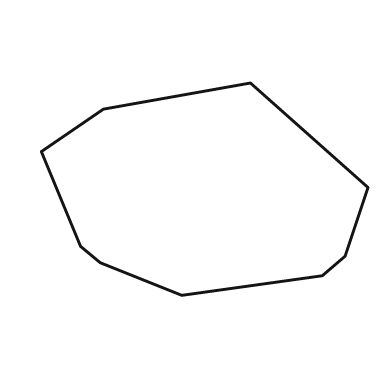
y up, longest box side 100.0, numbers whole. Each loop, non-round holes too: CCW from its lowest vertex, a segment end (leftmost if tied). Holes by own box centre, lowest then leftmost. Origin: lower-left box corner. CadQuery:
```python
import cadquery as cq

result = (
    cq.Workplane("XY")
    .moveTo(43.0, 0.0)
    .lineTo(86.0, 6.0)
    .lineTo(93.0, 12.0)
    .lineTo(100.0, 33.0)
    .lineTo(64.0, 65.0)
    .lineTo(19.0, 57.0)
    .lineTo(0.0, 44.0)
    .lineTo(12.0, 15.0)
    .lineTo(18.0, 10.0)
    .close()
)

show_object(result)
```